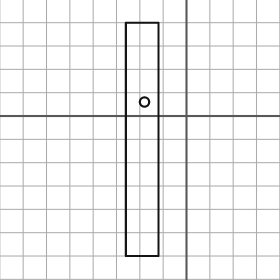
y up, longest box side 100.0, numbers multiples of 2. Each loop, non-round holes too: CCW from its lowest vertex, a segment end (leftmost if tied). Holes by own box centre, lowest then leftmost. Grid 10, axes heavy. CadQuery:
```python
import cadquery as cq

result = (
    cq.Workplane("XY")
    .moveTo(-26.0, -60.0)
    .lineTo(-12.0, -60.0)
    .lineTo(-12.0, 40.0)
    .lineTo(-26.0, 40.0)
    .close()
    .moveTo(-18.0, 6.0)
    .circle(2.0)
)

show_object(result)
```